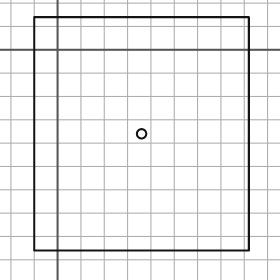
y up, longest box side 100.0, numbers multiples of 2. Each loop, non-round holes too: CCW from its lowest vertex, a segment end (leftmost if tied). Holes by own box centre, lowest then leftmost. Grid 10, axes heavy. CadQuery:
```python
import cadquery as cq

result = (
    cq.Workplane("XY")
    .moveTo(-10.0, -86.0)
    .lineTo(82.0, -86.0)
    .lineTo(82.0, 14.0)
    .lineTo(-10.0, 14.0)
    .close()
    .moveTo(36.0, -36.0)
    .circle(2.0)
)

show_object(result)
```